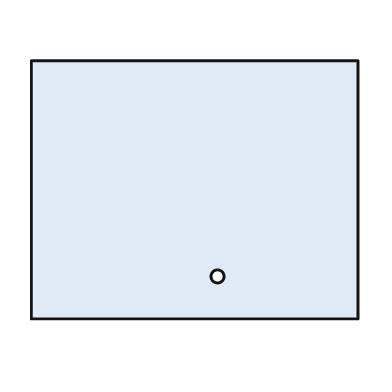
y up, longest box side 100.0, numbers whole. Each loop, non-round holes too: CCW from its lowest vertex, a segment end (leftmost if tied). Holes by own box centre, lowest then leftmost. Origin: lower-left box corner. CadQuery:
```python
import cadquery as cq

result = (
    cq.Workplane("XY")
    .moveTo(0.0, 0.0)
    .lineTo(100.0, 0.0)
    .lineTo(100.0, 79.0)
    .lineTo(0.0, 79.0)
    .close()
    .moveTo(57.0, 13.0)
    .circle(2.0)
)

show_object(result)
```